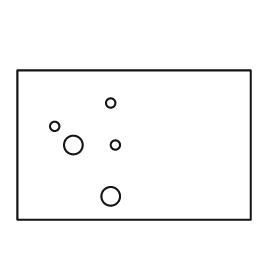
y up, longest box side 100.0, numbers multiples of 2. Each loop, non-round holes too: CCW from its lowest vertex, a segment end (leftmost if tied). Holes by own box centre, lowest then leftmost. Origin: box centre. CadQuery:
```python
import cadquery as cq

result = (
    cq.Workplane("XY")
    .moveTo(-50.0, -32.0)
    .lineTo(50.0, -32.0)
    .lineTo(50.0, 32.0)
    .lineTo(-50.0, 32.0)
    .close()
    .moveTo(-10.0, -22.0)
    .circle(4.0)
    .moveTo(-26.0, 0.0)
    .circle(4.0)
    .moveTo(-8.0, 0.0)
    .circle(2.0)
    .moveTo(-34.0, 8.0)
    .circle(2.0)
    .moveTo(-10.0, 18.0)
    .circle(2.0)
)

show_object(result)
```